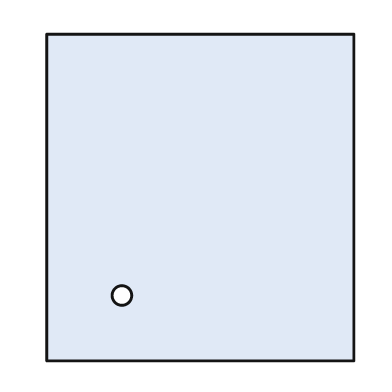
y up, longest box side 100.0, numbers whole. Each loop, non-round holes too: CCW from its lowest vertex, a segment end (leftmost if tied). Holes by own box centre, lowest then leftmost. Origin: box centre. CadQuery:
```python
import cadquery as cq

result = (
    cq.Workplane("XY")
    .moveTo(-47.0, -50.0)
    .lineTo(47.0, -50.0)
    .lineTo(47.0, 50.0)
    .lineTo(-47.0, 50.0)
    .close()
    .moveTo(-24.0, -30.0)
    .circle(3.0)
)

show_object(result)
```